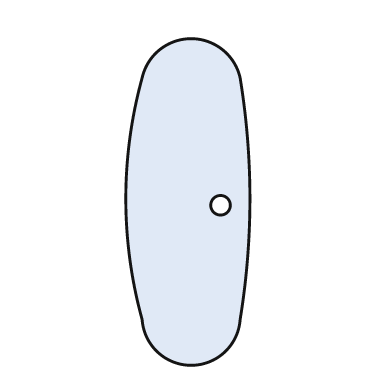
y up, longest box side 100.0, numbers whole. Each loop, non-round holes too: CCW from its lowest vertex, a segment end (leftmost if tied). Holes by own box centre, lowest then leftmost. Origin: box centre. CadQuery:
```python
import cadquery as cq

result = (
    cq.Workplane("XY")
    .moveTo(-14.0, -36.0)
    .threePointArc((1.0, -50.0), (16.0, -36.0))
    .threePointArc((19.0, 1.0), (16.0, 38.0))
    .threePointArc((1.0, 50.0), (-14.0, 38.0))
    .threePointArc((-19.0, 1.0), (-14.0, -36.0))
    .close()
    .moveTo(10.0, -1.0)
    .circle(3.0)
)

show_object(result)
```